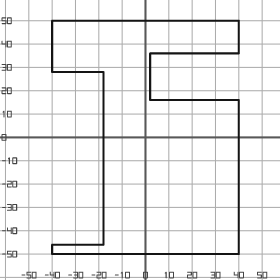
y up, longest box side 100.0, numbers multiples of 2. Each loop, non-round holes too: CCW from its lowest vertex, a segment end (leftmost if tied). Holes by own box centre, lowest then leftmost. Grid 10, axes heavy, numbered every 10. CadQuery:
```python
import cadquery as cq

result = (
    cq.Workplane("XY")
    .moveTo(-40.0, -50.0)
    .lineTo(40.0, -50.0)
    .lineTo(40.0, 16.0)
    .lineTo(2.0, 16.0)
    .lineTo(2.0, 36.0)
    .lineTo(40.0, 36.0)
    .lineTo(40.0, 50.0)
    .lineTo(-40.0, 50.0)
    .lineTo(-40.0, 28.0)
    .lineTo(-18.0, 28.0)
    .lineTo(-18.0, -46.0)
    .lineTo(-40.0, -46.0)
    .close()
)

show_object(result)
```